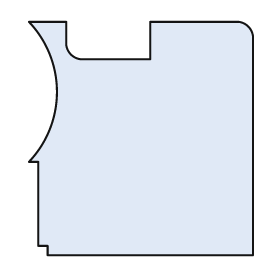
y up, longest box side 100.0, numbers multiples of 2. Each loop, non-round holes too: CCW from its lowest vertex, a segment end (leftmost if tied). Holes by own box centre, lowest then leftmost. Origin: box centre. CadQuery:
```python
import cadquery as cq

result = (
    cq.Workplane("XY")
    .moveTo(-40.0, -50.0)
    .lineTo(48.0, -50.0)
    .lineTo(48.0, 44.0)
    .threePointArc((46.0, 48.0), (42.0, 50.0))
    .lineTo(4.0, 50.0)
    .lineTo(4.0, 34.0)
    .lineTo(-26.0, 34.0)
    .threePointArc((-30.0, 36.0), (-32.0, 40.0))
    .lineTo(-32.0, 50.0)
    .lineTo(-48.0, 50.0)
    .threePointArc((-36.0, 20.0), (-48.0, -10.0))
    .lineTo(-44.0, -10.0)
    .lineTo(-44.0, -46.0)
    .lineTo(-40.0, -46.0)
    .close()
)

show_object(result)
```